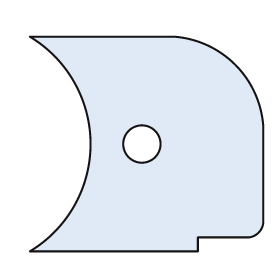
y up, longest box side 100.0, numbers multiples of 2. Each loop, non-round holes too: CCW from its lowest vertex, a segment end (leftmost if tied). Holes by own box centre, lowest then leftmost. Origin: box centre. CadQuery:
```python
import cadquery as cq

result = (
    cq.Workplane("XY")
    .moveTo(-50.0, -46.0)
    .lineTo(22.0, -46.0)
    .lineTo(22.0, -40.0)
    .lineTo(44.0, -40.0)
    .threePointArc((48.0, -38.0), (50.0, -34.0))
    .lineTo(50.0, 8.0)
    .threePointArc((38.0, 34.0), (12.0, 46.0))
    .lineTo(-50.0, 46.0)
    .threePointArc((-24.0, 0.0), (-50.0, -46.0))
    .close()
    .moveTo(-2.0, 0.0)
    .circle(8.0)
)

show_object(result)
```